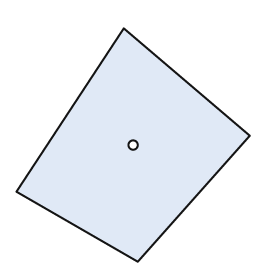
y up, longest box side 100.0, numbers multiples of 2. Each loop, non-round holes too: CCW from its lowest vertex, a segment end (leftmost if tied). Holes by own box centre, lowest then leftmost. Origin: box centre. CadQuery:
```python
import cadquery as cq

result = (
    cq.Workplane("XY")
    .moveTo(2.0, -50.0)
    .lineTo(50.0, 4.0)
    .lineTo(-4.0, 50.0)
    .lineTo(-50.0, -20.0)
    .close()
    .moveTo(0.0, 0.0)
    .circle(2.0)
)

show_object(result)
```